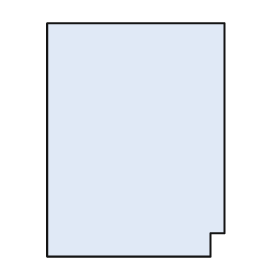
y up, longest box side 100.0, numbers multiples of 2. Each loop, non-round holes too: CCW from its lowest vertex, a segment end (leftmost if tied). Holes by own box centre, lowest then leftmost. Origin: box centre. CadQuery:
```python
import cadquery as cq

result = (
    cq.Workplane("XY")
    .moveTo(-38.0, -50.0)
    .lineTo(32.0, -50.0)
    .lineTo(32.0, -40.0)
    .lineTo(38.0, -40.0)
    .lineTo(38.0, 50.0)
    .lineTo(-38.0, 50.0)
    .close()
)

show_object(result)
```